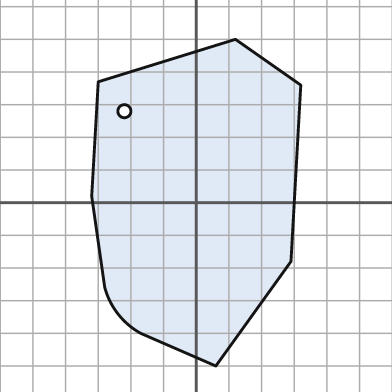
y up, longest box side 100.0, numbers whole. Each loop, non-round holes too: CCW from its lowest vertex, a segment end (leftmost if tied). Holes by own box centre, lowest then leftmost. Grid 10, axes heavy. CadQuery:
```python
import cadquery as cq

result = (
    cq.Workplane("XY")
    .moveTo(6.0, -50.0)
    .lineTo(29.0, -18.0)
    .lineTo(32.0, 36.0)
    .lineTo(12.0, 50.0)
    .lineTo(-30.0, 37.0)
    .lineTo(-32.0, 2.0)
    .lineTo(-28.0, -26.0)
    .threePointArc((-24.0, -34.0), (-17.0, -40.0))
    .close()
    .moveTo(-22.0, 28.0)
    .circle(2.0)
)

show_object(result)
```